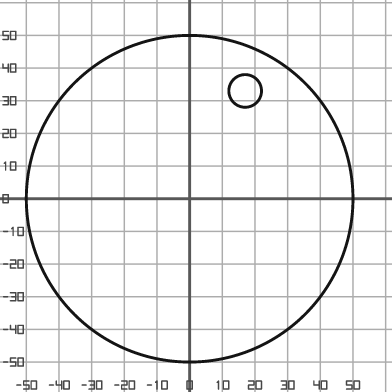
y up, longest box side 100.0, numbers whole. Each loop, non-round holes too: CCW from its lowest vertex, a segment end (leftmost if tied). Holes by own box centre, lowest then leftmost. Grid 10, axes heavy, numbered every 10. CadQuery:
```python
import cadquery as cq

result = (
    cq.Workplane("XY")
    .moveTo(0.0, 0.0)
    .circle(50.0)
    .moveTo(17.0, 33.0)
    .circle(5.0)
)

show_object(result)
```